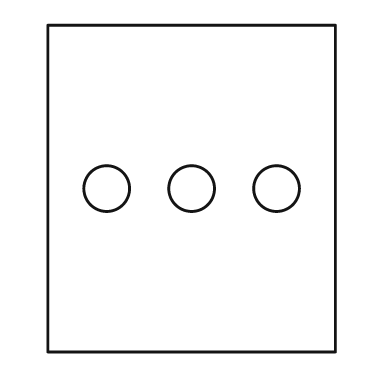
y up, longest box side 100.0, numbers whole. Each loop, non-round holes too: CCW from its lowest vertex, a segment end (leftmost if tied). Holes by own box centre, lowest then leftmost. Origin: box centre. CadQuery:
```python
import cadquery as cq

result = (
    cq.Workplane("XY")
    .moveTo(-44.0, -50.0)
    .lineTo(44.0, -50.0)
    .lineTo(44.0, 50.0)
    .lineTo(-44.0, 50.0)
    .close()
    .moveTo(-26.0, 0.0)
    .circle(7.0)
    .moveTo(0.0, 0.0)
    .circle(7.0)
    .moveTo(26.0, 0.0)
    .circle(7.0)
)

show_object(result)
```